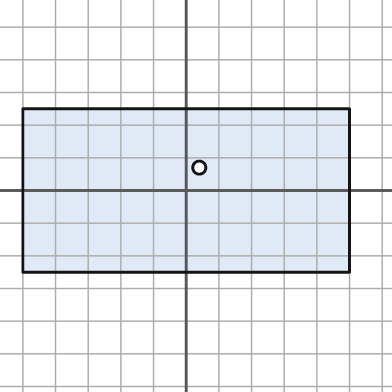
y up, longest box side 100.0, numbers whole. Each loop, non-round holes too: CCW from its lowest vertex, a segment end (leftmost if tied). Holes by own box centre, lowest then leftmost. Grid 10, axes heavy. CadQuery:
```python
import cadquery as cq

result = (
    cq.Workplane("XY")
    .moveTo(-50.0, -25.0)
    .lineTo(50.0, -25.0)
    .lineTo(50.0, 25.0)
    .lineTo(-50.0, 25.0)
    .close()
    .moveTo(4.0, 7.0)
    .circle(2.0)
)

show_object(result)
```